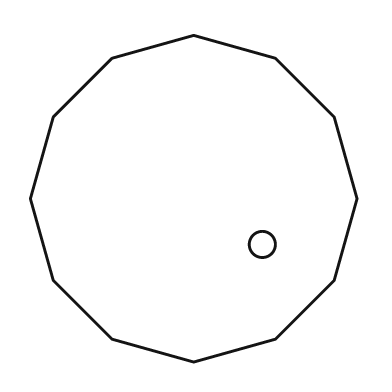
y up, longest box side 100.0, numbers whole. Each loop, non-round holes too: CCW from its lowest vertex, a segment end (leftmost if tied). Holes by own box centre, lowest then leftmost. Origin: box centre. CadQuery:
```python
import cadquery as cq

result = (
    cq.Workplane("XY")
    .moveTo(0.0, -50.0)
    .lineTo(25.0, -43.0)
    .lineTo(43.0, -25.0)
    .lineTo(50.0, 0.0)
    .lineTo(43.0, 25.0)
    .lineTo(25.0, 43.0)
    .lineTo(0.0, 50.0)
    .lineTo(-25.0, 43.0)
    .lineTo(-43.0, 25.0)
    .lineTo(-50.0, 0.0)
    .lineTo(-43.0, -25.0)
    .lineTo(-25.0, -43.0)
    .close()
    .moveTo(21.0, -14.0)
    .circle(4.0)
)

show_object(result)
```